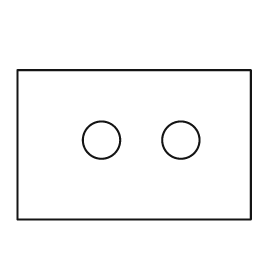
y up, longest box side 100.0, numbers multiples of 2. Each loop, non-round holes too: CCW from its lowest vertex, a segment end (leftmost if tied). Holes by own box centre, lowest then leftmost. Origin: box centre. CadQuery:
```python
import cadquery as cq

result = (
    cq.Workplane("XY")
    .moveTo(-50.0, -32.0)
    .lineTo(50.0, -32.0)
    .lineTo(50.0, 32.0)
    .lineTo(-50.0, 32.0)
    .close()
    .moveTo(-14.0, 2.0)
    .circle(8.0)
    .moveTo(20.0, 2.0)
    .circle(8.0)
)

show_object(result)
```